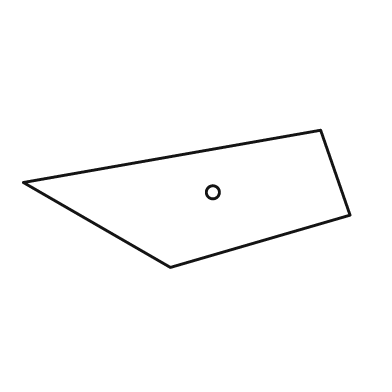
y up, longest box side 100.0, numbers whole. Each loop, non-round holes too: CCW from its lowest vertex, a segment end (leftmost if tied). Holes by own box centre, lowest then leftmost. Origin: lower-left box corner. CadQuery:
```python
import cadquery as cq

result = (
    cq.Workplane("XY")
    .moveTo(45.0, 0.0)
    .lineTo(100.0, 16.0)
    .lineTo(91.0, 42.0)
    .lineTo(0.0, 26.0)
    .close()
    .moveTo(58.0, 23.0)
    .circle(2.0)
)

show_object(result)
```